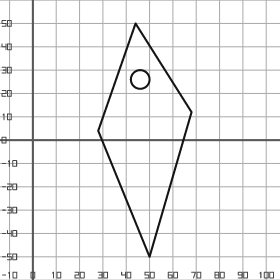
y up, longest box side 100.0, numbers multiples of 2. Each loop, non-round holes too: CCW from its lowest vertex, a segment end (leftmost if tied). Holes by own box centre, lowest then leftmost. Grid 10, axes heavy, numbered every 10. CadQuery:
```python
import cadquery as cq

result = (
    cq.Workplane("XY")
    .moveTo(50.0, -50.0)
    .lineTo(68.0, 12.0)
    .lineTo(44.0, 50.0)
    .lineTo(28.0, 4.0)
    .close()
    .moveTo(46.0, 26.0)
    .circle(4.0)
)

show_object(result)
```